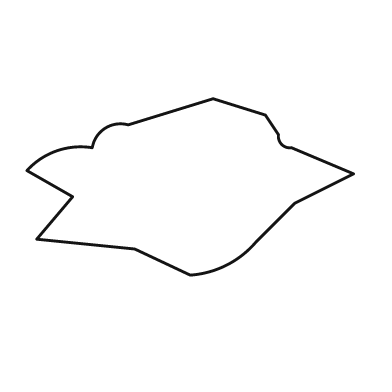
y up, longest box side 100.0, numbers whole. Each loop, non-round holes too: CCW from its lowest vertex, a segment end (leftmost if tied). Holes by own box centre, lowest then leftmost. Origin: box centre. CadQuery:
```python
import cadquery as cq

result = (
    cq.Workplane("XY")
    .moveTo(0.0, -27.0)
    .threePointArc((11.0, -24.0), (20.0, -17.0))
    .lineTo(32.0, -5.0)
    .lineTo(50.0, 4.0)
    .lineTo(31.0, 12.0)
    .threePointArc((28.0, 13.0), (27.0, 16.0))
    .lineTo(23.0, 22.0)
    .lineTo(7.0, 27.0)
    .lineTo(-19.0, 19.0)
    .threePointArc((-26.0, 18.0), (-30.0, 12.0))
    .threePointArc((-41.0, 11.0), (-50.0, 5.0))
    .lineTo(-36.0, -3.0)
    .lineTo(-47.0, -16.0)
    .lineTo(-17.0, -19.0)
    .close()
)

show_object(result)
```